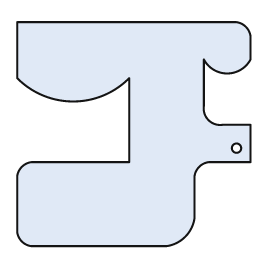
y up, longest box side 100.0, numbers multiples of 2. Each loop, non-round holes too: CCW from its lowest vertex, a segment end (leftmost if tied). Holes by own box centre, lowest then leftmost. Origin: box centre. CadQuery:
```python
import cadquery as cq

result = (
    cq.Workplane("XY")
    .moveTo(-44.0, -48.0)
    .lineTo(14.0, -48.0)
    .threePointArc((22.0, -44.0), (26.0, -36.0))
    .lineTo(26.0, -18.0)
    .threePointArc((28.0, -14.0), (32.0, -12.0))
    .lineTo(50.0, -12.0)
    .lineTo(50.0, 4.0)
    .lineTo(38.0, 4.0)
    .threePointArc((32.0, 6.0), (30.0, 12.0))
    .lineTo(30.0, 32.0)
    .threePointArc((40.0, 26.0), (50.0, 32.0))
    .lineTo(50.0, 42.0)
    .threePointArc((48.0, 46.0), (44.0, 48.0))
    .lineTo(-50.0, 48.0)
    .lineTo(-50.0, 24.0)
    .threePointArc((-26.0, 14.0), (-2.0, 24.0))
    .lineTo(-2.0, -12.0)
    .lineTo(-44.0, -12.0)
    .threePointArc((-48.0, -14.0), (-50.0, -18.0))
    .lineTo(-50.0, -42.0)
    .threePointArc((-48.0, -46.0), (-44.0, -48.0))
    .close()
    .moveTo(44.0, -6.0)
    .circle(2.0)
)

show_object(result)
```